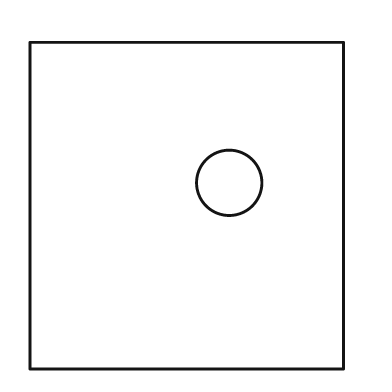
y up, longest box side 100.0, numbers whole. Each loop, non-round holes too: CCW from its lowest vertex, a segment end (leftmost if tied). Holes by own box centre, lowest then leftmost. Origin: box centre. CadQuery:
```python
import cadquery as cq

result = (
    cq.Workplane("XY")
    .moveTo(-48.0, -50.0)
    .lineTo(48.0, -50.0)
    .lineTo(48.0, 50.0)
    .lineTo(-48.0, 50.0)
    .close()
    .moveTo(13.0, 7.0)
    .circle(10.0)
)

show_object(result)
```